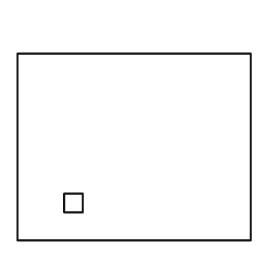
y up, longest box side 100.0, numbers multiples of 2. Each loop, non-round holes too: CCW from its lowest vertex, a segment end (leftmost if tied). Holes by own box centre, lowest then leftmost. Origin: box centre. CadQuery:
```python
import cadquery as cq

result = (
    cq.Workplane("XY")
    .moveTo(-50.0, -40.0)
    .lineTo(50.0, -40.0)
    .lineTo(50.0, 40.0)
    .lineTo(-50.0, 40.0)
    .close()
    .moveTo(-30.0, -28.0)
    .lineTo(-22.0, -28.0)
    .lineTo(-22.0, -20.0)
    .lineTo(-30.0, -20.0)
    .close()
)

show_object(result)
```